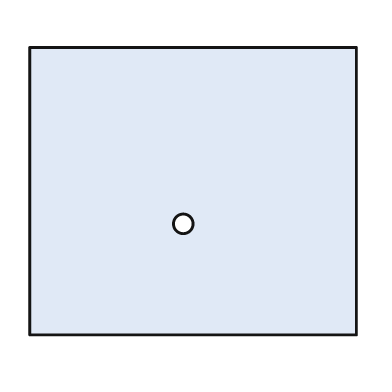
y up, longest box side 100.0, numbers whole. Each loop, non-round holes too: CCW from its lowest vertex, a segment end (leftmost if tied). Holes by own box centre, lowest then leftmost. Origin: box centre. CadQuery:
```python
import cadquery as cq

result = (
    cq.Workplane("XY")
    .moveTo(-50.0, -44.0)
    .lineTo(50.0, -44.0)
    .lineTo(50.0, 44.0)
    .lineTo(-50.0, 44.0)
    .close()
    .moveTo(-3.0, -10.0)
    .circle(3.0)
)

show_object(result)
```